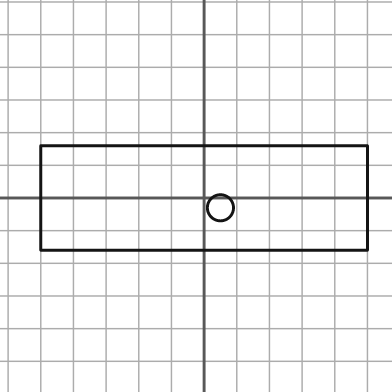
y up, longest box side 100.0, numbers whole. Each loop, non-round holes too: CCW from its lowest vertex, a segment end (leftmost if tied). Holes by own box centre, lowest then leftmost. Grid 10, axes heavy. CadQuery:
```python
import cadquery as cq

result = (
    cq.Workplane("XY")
    .moveTo(-50.0, -16.0)
    .lineTo(50.0, -16.0)
    .lineTo(50.0, 16.0)
    .lineTo(-50.0, 16.0)
    .close()
    .moveTo(5.0, -3.0)
    .circle(4.0)
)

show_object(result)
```